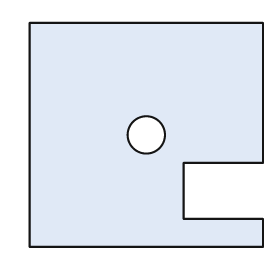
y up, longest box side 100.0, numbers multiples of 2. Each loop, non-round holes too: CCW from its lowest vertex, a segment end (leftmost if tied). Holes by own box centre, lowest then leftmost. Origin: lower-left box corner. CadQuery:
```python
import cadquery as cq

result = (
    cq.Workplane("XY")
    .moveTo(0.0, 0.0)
    .lineTo(100.0, 0.0)
    .lineTo(100.0, 12.0)
    .lineTo(66.0, 12.0)
    .lineTo(66.0, 36.0)
    .lineTo(100.0, 36.0)
    .lineTo(100.0, 96.0)
    .lineTo(0.0, 96.0)
    .close()
    .moveTo(50.0, 48.0)
    .circle(8.0)
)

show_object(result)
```